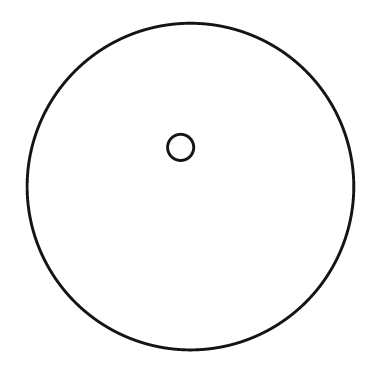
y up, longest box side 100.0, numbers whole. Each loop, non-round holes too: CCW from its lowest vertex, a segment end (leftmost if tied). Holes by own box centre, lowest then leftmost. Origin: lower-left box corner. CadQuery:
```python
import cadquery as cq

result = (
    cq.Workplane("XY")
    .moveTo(50.0, 50.0)
    .circle(50.0)
    .moveTo(47.0, 62.0)
    .circle(4.0)
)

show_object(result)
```